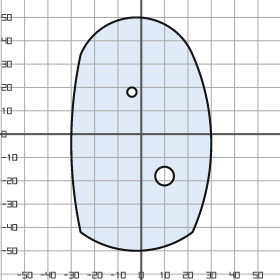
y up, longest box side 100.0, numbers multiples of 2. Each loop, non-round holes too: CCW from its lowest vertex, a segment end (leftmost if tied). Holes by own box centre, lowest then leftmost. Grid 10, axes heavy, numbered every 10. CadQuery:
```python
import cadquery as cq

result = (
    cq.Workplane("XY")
    .moveTo(-26.0, -42.0)
    .threePointArc((-2.0, -50.0), (22.0, -42.0))
    .threePointArc((30.0, -4.0), (22.0, 34.0))
    .threePointArc((-2.0, 50.0), (-26.0, 34.0))
    .threePointArc((-30.0, -4.0), (-26.0, -42.0))
    .close()
    .moveTo(10.0, -18.0)
    .circle(4.0)
    .moveTo(-4.0, 18.0)
    .circle(2.0)
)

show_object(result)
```